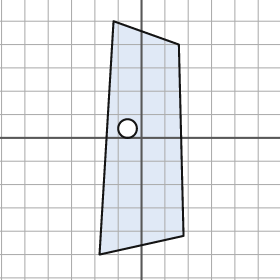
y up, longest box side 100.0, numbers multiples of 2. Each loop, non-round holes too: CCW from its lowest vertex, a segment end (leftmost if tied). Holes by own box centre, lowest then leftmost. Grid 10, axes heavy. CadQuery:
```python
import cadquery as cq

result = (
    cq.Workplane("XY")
    .moveTo(-18.0, -50.0)
    .lineTo(18.0, -42.0)
    .lineTo(16.0, 40.0)
    .lineTo(-12.0, 50.0)
    .close()
    .moveTo(-6.0, 4.0)
    .circle(4.0)
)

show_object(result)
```